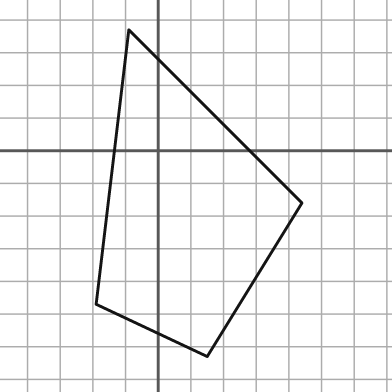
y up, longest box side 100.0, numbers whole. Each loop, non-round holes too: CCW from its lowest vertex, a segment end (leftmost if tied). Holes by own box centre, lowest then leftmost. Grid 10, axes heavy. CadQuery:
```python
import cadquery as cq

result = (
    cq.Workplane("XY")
    .moveTo(15.0, -63.0)
    .lineTo(44.0, -16.0)
    .lineTo(-9.0, 37.0)
    .lineTo(-19.0, -47.0)
    .close()
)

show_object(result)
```